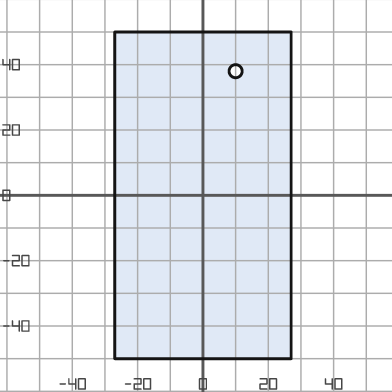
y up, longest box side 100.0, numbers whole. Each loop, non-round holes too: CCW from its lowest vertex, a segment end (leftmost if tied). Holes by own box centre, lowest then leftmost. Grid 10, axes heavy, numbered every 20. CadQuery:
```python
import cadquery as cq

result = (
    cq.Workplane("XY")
    .moveTo(-27.0, -50.0)
    .lineTo(27.0, -50.0)
    .lineTo(27.0, 50.0)
    .lineTo(-27.0, 50.0)
    .close()
    .moveTo(10.0, 38.0)
    .circle(2.0)
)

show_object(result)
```